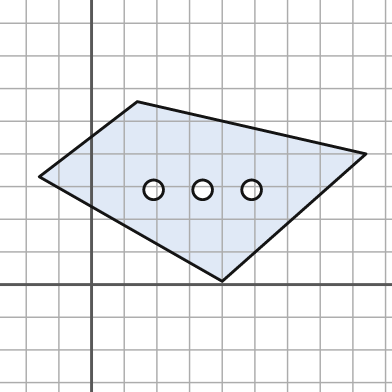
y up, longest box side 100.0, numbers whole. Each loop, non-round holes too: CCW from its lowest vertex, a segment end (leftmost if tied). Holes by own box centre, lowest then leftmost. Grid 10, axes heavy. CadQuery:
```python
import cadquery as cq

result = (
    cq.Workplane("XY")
    .moveTo(40.0, 1.0)
    .lineTo(84.0, 40.0)
    .lineTo(14.0, 56.0)
    .lineTo(-16.0, 33.0)
    .close()
    .moveTo(19.0, 29.0)
    .circle(3.0)
    .moveTo(34.0, 29.0)
    .circle(3.0)
    .moveTo(49.0, 29.0)
    .circle(3.0)
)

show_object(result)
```